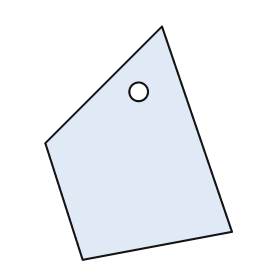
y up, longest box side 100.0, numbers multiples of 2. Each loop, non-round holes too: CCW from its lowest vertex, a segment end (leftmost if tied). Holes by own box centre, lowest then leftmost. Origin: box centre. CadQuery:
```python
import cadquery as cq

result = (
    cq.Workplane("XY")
    .moveTo(-24.0, -50.0)
    .lineTo(40.0, -38.0)
    .lineTo(10.0, 50.0)
    .lineTo(-40.0, 0.0)
    .close()
    .moveTo(0.0, 22.0)
    .circle(4.0)
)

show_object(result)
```